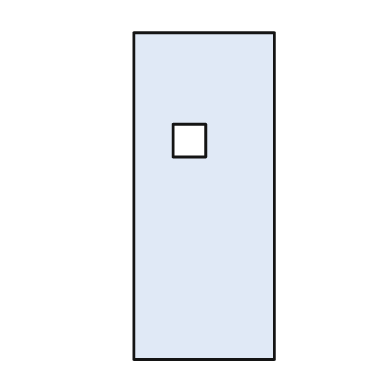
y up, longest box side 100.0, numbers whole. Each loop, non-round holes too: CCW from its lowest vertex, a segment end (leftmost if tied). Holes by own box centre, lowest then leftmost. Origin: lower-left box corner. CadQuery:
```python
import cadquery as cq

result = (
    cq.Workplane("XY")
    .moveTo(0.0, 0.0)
    .lineTo(43.0, 0.0)
    .lineTo(43.0, 100.0)
    .lineTo(0.0, 100.0)
    .close()
    .moveTo(12.0, 62.0)
    .lineTo(22.0, 62.0)
    .lineTo(22.0, 72.0)
    .lineTo(12.0, 72.0)
    .close()
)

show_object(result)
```